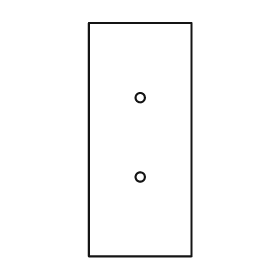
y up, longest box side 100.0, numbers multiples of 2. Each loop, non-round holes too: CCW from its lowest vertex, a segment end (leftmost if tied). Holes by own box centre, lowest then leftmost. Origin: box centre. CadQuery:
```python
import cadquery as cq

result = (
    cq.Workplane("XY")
    .moveTo(-22.0, -50.0)
    .lineTo(22.0, -50.0)
    .lineTo(22.0, 50.0)
    .lineTo(-22.0, 50.0)
    .close()
    .moveTo(0.0, -16.0)
    .circle(2.0)
    .moveTo(0.0, 18.0)
    .circle(2.0)
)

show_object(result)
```